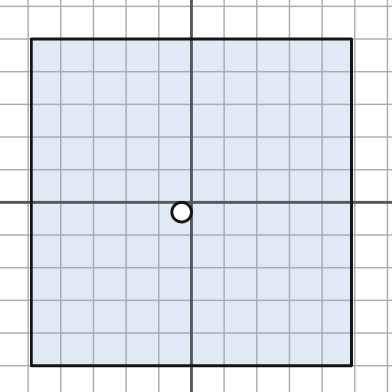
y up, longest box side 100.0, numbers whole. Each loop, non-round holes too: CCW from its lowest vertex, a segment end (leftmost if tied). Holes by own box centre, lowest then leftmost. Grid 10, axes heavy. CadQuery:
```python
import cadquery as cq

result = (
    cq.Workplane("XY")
    .moveTo(-49.0, -50.0)
    .lineTo(49.0, -50.0)
    .lineTo(49.0, 50.0)
    .lineTo(-49.0, 50.0)
    .close()
    .moveTo(-3.0, -3.0)
    .circle(3.0)
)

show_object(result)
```